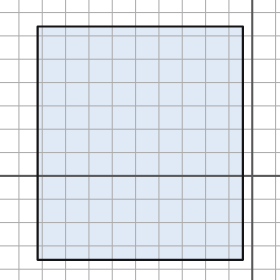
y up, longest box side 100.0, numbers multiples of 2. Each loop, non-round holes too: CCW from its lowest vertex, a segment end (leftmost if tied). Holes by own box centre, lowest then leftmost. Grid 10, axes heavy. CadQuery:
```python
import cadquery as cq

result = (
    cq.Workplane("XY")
    .moveTo(-92.0, -36.0)
    .lineTo(-4.0, -36.0)
    .lineTo(-4.0, 64.0)
    .lineTo(-92.0, 64.0)
    .close()
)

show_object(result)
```